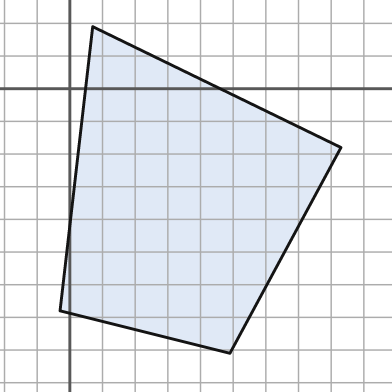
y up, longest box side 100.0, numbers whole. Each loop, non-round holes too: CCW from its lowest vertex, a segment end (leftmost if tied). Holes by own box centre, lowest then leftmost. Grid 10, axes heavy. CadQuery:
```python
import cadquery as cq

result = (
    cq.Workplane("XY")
    .moveTo(49.0, -81.0)
    .lineTo(83.0, -18.0)
    .lineTo(7.0, 19.0)
    .lineTo(-3.0, -68.0)
    .close()
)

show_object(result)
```